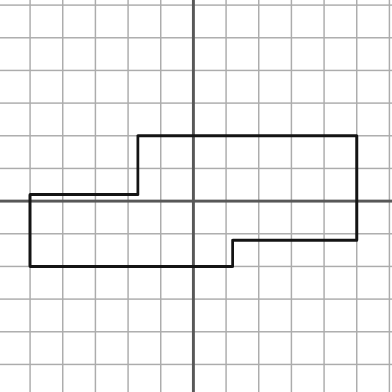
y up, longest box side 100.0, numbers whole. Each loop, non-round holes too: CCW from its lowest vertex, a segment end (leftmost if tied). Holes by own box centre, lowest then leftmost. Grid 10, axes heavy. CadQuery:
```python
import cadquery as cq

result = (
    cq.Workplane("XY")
    .moveTo(-50.0, -20.0)
    .lineTo(12.0, -20.0)
    .lineTo(12.0, -12.0)
    .lineTo(50.0, -12.0)
    .lineTo(50.0, 20.0)
    .lineTo(-17.0, 20.0)
    .lineTo(-17.0, 2.0)
    .lineTo(-50.0, 2.0)
    .close()
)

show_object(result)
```